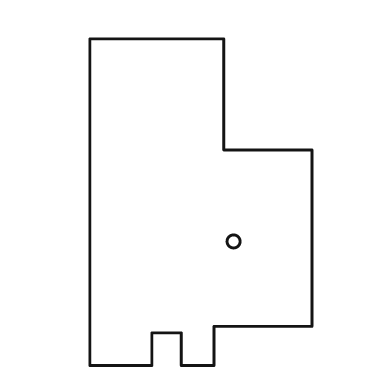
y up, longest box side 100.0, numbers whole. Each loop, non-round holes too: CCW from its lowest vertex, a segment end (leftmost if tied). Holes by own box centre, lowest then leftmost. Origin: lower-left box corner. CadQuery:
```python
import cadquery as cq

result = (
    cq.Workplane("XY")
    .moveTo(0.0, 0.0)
    .lineTo(19.0, 0.0)
    .lineTo(19.0, 10.0)
    .lineTo(28.0, 10.0)
    .lineTo(28.0, 0.0)
    .lineTo(38.0, 0.0)
    .lineTo(38.0, 12.0)
    .lineTo(68.0, 12.0)
    .lineTo(68.0, 66.0)
    .lineTo(41.0, 66.0)
    .lineTo(41.0, 100.0)
    .lineTo(0.0, 100.0)
    .close()
    .moveTo(44.0, 38.0)
    .circle(2.0)
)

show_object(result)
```